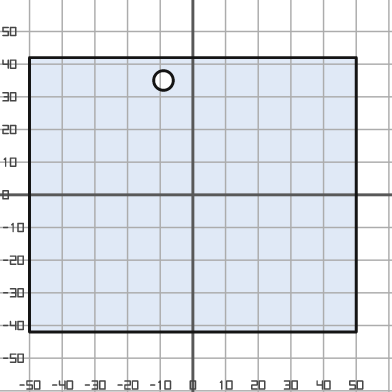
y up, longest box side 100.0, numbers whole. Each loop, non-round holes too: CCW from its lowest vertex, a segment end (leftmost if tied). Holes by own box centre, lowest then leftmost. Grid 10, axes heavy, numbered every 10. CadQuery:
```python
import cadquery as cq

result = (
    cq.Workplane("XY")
    .moveTo(-50.0, -42.0)
    .lineTo(50.0, -42.0)
    .lineTo(50.0, 42.0)
    .lineTo(-50.0, 42.0)
    .close()
    .moveTo(-9.0, 35.0)
    .circle(3.0)
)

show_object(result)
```